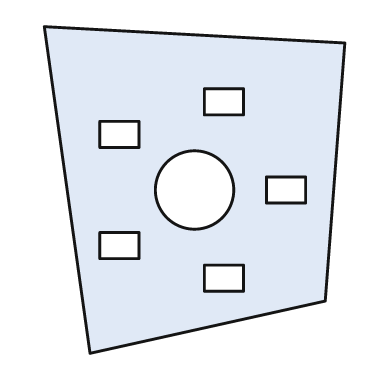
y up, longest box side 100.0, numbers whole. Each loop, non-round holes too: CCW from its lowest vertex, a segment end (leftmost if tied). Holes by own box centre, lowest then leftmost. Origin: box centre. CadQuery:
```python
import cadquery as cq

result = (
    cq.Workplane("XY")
    .moveTo(-32.0, -50.0)
    .lineTo(40.0, -34.0)
    .lineTo(46.0, 45.0)
    .lineTo(-46.0, 50.0)
    .close()
    .moveTo(3.0, -31.0)
    .lineTo(15.0, -31.0)
    .lineTo(15.0, -23.0)
    .lineTo(3.0, -23.0)
    .close()
    .moveTo(-29.0, -21.0)
    .lineTo(-17.0, -21.0)
    .lineTo(-17.0, -13.0)
    .lineTo(-29.0, -13.0)
    .close()
    .moveTo(0.0, 0.0)
    .circle(12.0)
    .moveTo(22.0, -4.0)
    .lineTo(34.0, -4.0)
    .lineTo(34.0, 4.0)
    .lineTo(22.0, 4.0)
    .close()
    .moveTo(-29.0, 13.0)
    .lineTo(-17.0, 13.0)
    .lineTo(-17.0, 21.0)
    .lineTo(-29.0, 21.0)
    .close()
    .moveTo(3.0, 23.0)
    .lineTo(15.0, 23.0)
    .lineTo(15.0, 31.0)
    .lineTo(3.0, 31.0)
    .close()
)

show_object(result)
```